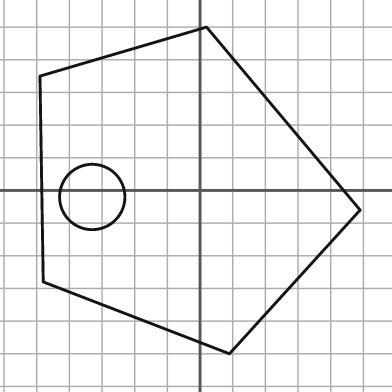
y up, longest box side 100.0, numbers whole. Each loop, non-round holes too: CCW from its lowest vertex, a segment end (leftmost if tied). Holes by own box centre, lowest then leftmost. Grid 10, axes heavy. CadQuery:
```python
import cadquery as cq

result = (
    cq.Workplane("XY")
    .moveTo(9.0, -50.0)
    .lineTo(49.0, -6.0)
    .lineTo(2.0, 50.0)
    .lineTo(-49.0, 35.0)
    .lineTo(-48.0, -28.0)
    .close()
    .moveTo(-33.0, -2.0)
    .circle(10.0)
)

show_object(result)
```